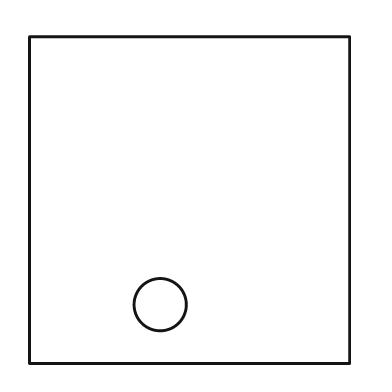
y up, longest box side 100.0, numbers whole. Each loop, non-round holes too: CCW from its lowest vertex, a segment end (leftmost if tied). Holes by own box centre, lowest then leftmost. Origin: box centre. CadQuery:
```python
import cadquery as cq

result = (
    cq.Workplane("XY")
    .moveTo(-49.0, -50.0)
    .lineTo(49.0, -50.0)
    .lineTo(49.0, 50.0)
    .lineTo(-49.0, 50.0)
    .close()
    .moveTo(-9.0, -32.0)
    .circle(8.0)
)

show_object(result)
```